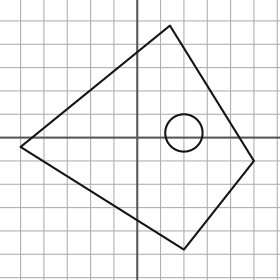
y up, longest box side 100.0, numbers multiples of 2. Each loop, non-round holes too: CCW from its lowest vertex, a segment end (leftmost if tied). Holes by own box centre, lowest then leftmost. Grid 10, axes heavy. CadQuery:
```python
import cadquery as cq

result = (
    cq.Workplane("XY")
    .moveTo(20.0, -48.0)
    .lineTo(50.0, -10.0)
    .lineTo(14.0, 48.0)
    .lineTo(-50.0, -4.0)
    .close()
    .moveTo(20.0, 2.0)
    .circle(8.0)
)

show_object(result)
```